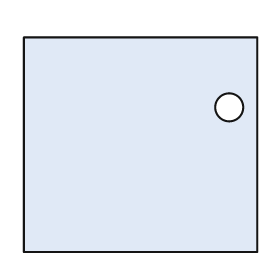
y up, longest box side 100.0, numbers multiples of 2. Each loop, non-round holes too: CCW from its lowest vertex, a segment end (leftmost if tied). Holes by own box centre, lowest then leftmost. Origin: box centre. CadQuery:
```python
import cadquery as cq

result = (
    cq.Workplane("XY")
    .moveTo(-50.0, -46.0)
    .lineTo(50.0, -46.0)
    .lineTo(50.0, 46.0)
    .lineTo(-50.0, 46.0)
    .close()
    .moveTo(38.0, 16.0)
    .circle(6.0)
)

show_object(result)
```